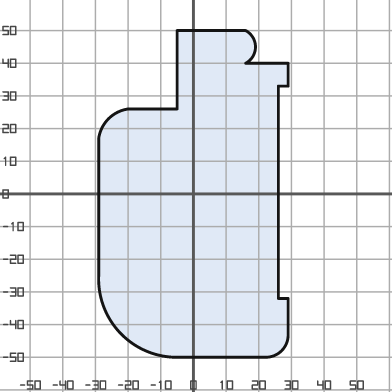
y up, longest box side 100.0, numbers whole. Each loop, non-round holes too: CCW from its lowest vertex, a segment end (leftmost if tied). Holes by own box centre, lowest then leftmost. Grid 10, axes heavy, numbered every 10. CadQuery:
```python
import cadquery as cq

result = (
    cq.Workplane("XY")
    .moveTo(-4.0, -50.0)
    .lineTo(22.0, -50.0)
    .threePointArc((27.0, -48.0), (29.0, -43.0))
    .lineTo(29.0, -32.0)
    .lineTo(26.0, -32.0)
    .lineTo(26.0, 33.0)
    .lineTo(29.0, 33.0)
    .lineTo(29.0, 40.0)
    .lineTo(16.0, 40.0)
    .threePointArc((19.0, 45.0), (16.0, 50.0))
    .lineTo(-5.0, 50.0)
    .lineTo(-5.0, 26.0)
    .lineTo(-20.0, 26.0)
    .threePointArc((-26.0, 23.0), (-29.0, 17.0))
    .lineTo(-29.0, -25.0)
    .threePointArc((-22.0, -43.0), (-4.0, -50.0))
    .close()
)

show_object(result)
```